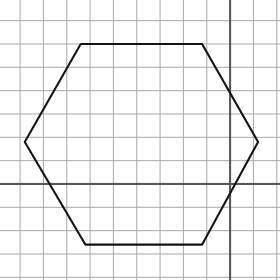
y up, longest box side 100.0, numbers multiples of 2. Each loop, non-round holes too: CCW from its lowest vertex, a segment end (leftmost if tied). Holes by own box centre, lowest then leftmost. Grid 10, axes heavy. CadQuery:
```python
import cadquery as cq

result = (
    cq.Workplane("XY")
    .moveTo(-62.0, -26.0)
    .lineTo(-12.0, -26.0)
    .lineTo(12.0, 18.0)
    .lineTo(-12.0, 60.0)
    .lineTo(-64.0, 60.0)
    .lineTo(-88.0, 18.0)
    .close()
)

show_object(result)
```